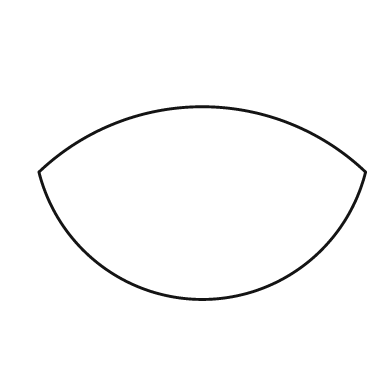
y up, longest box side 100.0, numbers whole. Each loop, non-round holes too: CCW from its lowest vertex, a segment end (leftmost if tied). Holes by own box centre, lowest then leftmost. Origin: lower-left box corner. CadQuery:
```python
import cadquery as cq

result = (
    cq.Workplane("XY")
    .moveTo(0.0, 39.0)
    .threePointArc((50.0, 0.0), (100.0, 39.0))
    .threePointArc((50.0, 59.0), (0.0, 39.0))
    .close()
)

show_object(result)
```